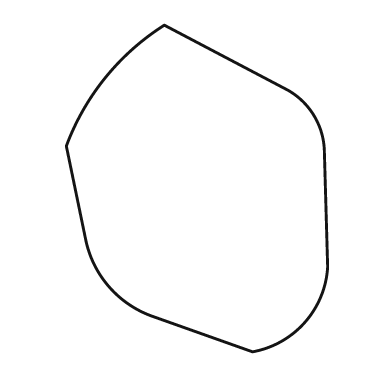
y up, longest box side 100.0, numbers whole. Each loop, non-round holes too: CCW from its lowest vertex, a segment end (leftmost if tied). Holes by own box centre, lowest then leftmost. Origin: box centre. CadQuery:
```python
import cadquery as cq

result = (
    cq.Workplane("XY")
    .moveTo(17.0, -50.0)
    .threePointArc((33.0, -41.0), (40.0, -24.0))
    .lineTo(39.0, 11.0)
    .threePointArc((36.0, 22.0), (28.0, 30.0))
    .lineTo(-10.0, 50.0)
    .threePointArc((-28.0, 34.0), (-40.0, 13.0))
    .lineTo(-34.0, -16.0)
    .threePointArc((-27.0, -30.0), (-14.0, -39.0))
    .close()
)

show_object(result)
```